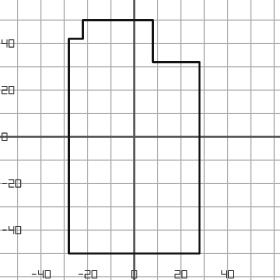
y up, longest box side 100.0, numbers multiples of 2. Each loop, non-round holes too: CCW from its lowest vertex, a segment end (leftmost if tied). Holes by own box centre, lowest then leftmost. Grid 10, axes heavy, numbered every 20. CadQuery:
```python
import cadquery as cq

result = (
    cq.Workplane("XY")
    .moveTo(-28.0, -50.0)
    .lineTo(28.0, -50.0)
    .lineTo(28.0, 32.0)
    .lineTo(8.0, 32.0)
    .lineTo(8.0, 50.0)
    .lineTo(-22.0, 50.0)
    .lineTo(-22.0, 42.0)
    .lineTo(-28.0, 42.0)
    .close()
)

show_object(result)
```